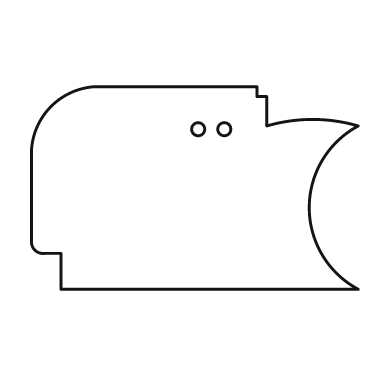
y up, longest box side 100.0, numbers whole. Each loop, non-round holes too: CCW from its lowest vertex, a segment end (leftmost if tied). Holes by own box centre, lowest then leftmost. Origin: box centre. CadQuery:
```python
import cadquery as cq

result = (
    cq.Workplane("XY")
    .moveTo(-41.0, -31.0)
    .lineTo(50.0, -31.0)
    .threePointArc((35.0, -6.0), (50.0, 19.0))
    .threePointArc((36.0, 21.0), (22.0, 19.0))
    .lineTo(22.0, 28.0)
    .lineTo(19.0, 28.0)
    .lineTo(19.0, 31.0)
    .lineTo(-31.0, 31.0)
    .threePointArc((-44.0, 25.0), (-50.0, 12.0))
    .lineTo(-50.0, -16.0)
    .threePointArc((-49.0, -19.0), (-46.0, -20.0))
    .lineTo(-41.0, -20.0)
    .close()
    .moveTo(1.0, 18.0)
    .circle(2.0)
    .moveTo(9.0, 18.0)
    .circle(2.0)
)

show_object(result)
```